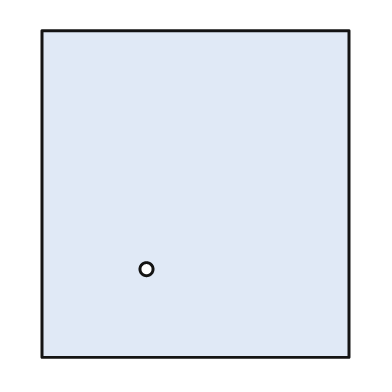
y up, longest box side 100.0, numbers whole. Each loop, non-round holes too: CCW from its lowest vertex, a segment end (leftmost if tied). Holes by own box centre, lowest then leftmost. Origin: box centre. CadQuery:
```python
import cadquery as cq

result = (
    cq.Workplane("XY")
    .moveTo(-47.0, -50.0)
    .lineTo(47.0, -50.0)
    .lineTo(47.0, 50.0)
    .lineTo(-47.0, 50.0)
    .close()
    .moveTo(-15.0, -23.0)
    .circle(2.0)
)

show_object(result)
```